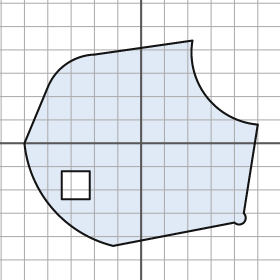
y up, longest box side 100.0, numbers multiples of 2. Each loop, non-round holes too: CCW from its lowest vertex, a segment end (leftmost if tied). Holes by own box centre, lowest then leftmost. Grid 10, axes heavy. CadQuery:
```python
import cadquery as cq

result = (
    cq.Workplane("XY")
    .moveTo(-12.0, -44.0)
    .lineTo(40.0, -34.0)
    .threePointArc((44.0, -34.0), (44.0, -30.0))
    .lineTo(50.0, 8.0)
    .threePointArc((28.0, 20.0), (22.0, 44.0))
    .lineTo(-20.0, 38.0)
    .threePointArc((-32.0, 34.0), (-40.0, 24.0))
    .lineTo(-50.0, 0.0)
    .threePointArc((-38.0, -28.0), (-12.0, -44.0))
    .close()
    .moveTo(-34.0, -24.0)
    .lineTo(-22.0, -24.0)
    .lineTo(-22.0, -12.0)
    .lineTo(-34.0, -12.0)
    .close()
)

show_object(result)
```